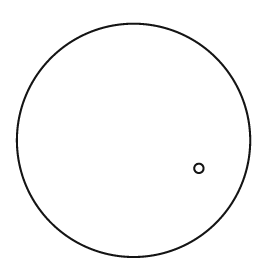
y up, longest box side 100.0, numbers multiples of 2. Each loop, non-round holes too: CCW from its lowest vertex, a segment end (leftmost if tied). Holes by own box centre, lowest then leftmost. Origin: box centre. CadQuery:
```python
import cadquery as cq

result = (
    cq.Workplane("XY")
    .moveTo(0.0, 0.0)
    .circle(50.0)
    .moveTo(28.0, -12.0)
    .circle(2.0)
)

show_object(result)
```